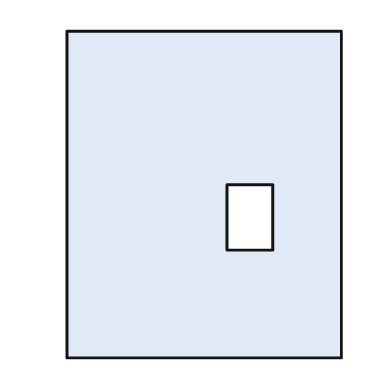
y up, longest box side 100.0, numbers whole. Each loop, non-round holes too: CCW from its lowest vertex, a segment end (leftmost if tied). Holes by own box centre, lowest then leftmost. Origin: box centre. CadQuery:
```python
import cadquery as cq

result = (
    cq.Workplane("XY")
    .moveTo(-42.0, -50.0)
    .lineTo(42.0, -50.0)
    .lineTo(42.0, 50.0)
    .lineTo(-42.0, 50.0)
    .close()
    .moveTo(7.0, -17.0)
    .lineTo(21.0, -17.0)
    .lineTo(21.0, 3.0)
    .lineTo(7.0, 3.0)
    .close()
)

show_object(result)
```